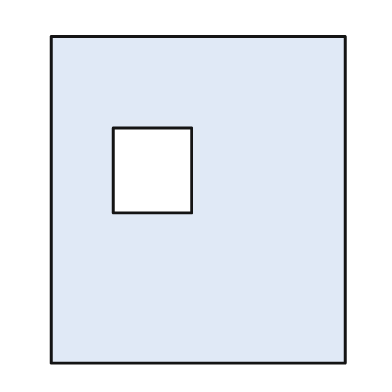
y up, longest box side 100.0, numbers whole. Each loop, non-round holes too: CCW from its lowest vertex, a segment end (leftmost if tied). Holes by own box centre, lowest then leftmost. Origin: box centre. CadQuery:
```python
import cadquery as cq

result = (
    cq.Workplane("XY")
    .moveTo(-45.0, -50.0)
    .lineTo(45.0, -50.0)
    .lineTo(45.0, 50.0)
    .lineTo(-45.0, 50.0)
    .close()
    .moveTo(-26.0, -4.0)
    .lineTo(-2.0, -4.0)
    .lineTo(-2.0, 22.0)
    .lineTo(-26.0, 22.0)
    .close()
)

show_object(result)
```